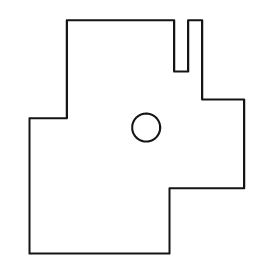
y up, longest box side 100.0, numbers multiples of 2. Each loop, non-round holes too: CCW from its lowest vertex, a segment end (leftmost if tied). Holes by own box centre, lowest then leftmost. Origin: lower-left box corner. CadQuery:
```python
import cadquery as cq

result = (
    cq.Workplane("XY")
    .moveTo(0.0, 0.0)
    .lineTo(60.0, 0.0)
    .lineTo(60.0, 28.0)
    .lineTo(92.0, 28.0)
    .lineTo(92.0, 66.0)
    .lineTo(74.0, 66.0)
    .lineTo(74.0, 100.0)
    .lineTo(68.0, 100.0)
    .lineTo(68.0, 78.0)
    .lineTo(62.0, 78.0)
    .lineTo(62.0, 100.0)
    .lineTo(16.0, 100.0)
    .lineTo(16.0, 58.0)
    .lineTo(0.0, 58.0)
    .close()
    .moveTo(50.0, 54.0)
    .circle(6.0)
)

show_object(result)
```